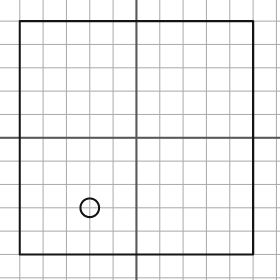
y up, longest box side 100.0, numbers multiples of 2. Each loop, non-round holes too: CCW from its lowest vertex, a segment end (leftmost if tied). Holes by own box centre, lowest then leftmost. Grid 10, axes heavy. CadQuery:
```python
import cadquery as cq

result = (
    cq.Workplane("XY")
    .moveTo(-50.0, -50.0)
    .lineTo(50.0, -50.0)
    .lineTo(50.0, 50.0)
    .lineTo(-50.0, 50.0)
    .close()
    .moveTo(-20.0, -30.0)
    .circle(4.0)
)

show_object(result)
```